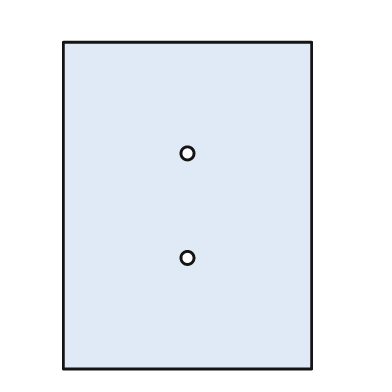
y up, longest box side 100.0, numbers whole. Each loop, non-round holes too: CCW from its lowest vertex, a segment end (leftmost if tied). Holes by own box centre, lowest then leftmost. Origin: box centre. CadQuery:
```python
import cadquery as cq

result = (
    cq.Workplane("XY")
    .moveTo(-38.0, -50.0)
    .lineTo(38.0, -50.0)
    .lineTo(38.0, 50.0)
    .lineTo(-38.0, 50.0)
    .close()
    .moveTo(0.0, -16.0)
    .circle(2.0)
    .moveTo(0.0, 16.0)
    .circle(2.0)
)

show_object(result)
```